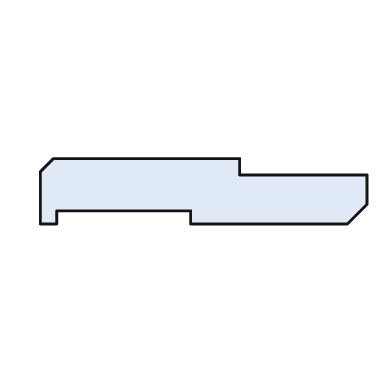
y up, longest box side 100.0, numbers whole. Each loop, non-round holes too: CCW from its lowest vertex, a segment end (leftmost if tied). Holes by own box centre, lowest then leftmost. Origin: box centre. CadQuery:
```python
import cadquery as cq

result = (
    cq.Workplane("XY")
    .moveTo(-50.0, -10.0)
    .lineTo(-45.0, -10.0)
    .lineTo(-45.0, -6.0)
    .lineTo(-4.0, -6.0)
    .lineTo(-4.0, -10.0)
    .lineTo(44.0, -10.0)
    .lineTo(50.0, -4.0)
    .lineTo(50.0, 5.0)
    .lineTo(11.0, 5.0)
    .lineTo(11.0, 10.0)
    .lineTo(-46.0, 10.0)
    .lineTo(-50.0, 6.0)
    .close()
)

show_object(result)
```